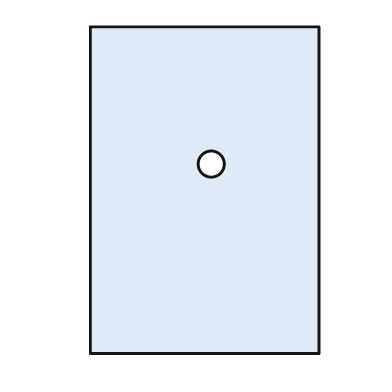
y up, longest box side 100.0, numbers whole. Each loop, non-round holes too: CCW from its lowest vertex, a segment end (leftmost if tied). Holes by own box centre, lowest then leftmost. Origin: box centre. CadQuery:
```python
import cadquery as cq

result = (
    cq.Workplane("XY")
    .moveTo(-35.0, -50.0)
    .lineTo(35.0, -50.0)
    .lineTo(35.0, 50.0)
    .lineTo(-35.0, 50.0)
    .close()
    .moveTo(2.0, 8.0)
    .circle(4.0)
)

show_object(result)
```